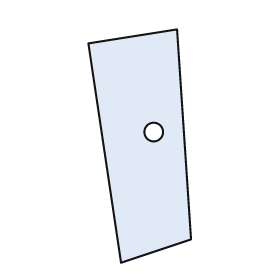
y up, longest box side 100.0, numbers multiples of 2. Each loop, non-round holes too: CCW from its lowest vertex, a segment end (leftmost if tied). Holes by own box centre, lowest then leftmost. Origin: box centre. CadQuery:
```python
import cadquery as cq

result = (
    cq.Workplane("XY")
    .moveTo(-8.0, -50.0)
    .lineTo(22.0, -40.0)
    .lineTo(16.0, 50.0)
    .lineTo(-22.0, 44.0)
    .close()
    .moveTo(6.0, 6.0)
    .circle(4.0)
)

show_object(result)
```